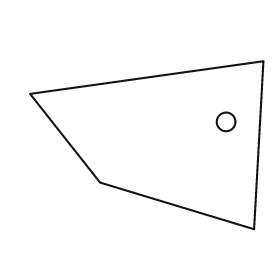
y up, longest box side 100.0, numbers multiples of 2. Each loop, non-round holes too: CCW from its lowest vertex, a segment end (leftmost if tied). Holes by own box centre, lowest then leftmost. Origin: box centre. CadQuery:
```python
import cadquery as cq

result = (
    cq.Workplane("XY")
    .moveTo(46.0, -36.0)
    .lineTo(50.0, 36.0)
    .lineTo(-50.0, 22.0)
    .lineTo(-20.0, -16.0)
    .close()
    .moveTo(34.0, 10.0)
    .circle(4.0)
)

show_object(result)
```